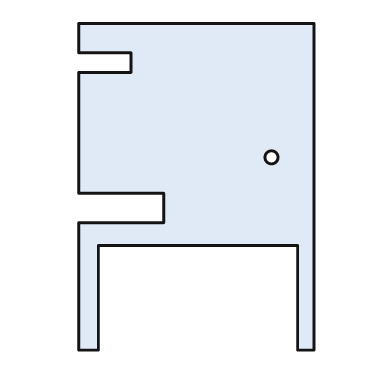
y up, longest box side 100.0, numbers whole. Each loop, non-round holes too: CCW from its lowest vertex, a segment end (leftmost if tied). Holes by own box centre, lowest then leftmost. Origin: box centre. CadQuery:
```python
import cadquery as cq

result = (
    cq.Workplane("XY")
    .moveTo(-36.0, -50.0)
    .lineTo(-30.0, -50.0)
    .lineTo(-30.0, -18.0)
    .lineTo(31.0, -18.0)
    .lineTo(31.0, -50.0)
    .lineTo(36.0, -50.0)
    .lineTo(36.0, 50.0)
    .lineTo(-36.0, 50.0)
    .lineTo(-36.0, 41.0)
    .lineTo(-20.0, 41.0)
    .lineTo(-20.0, 35.0)
    .lineTo(-36.0, 35.0)
    .lineTo(-36.0, -2.0)
    .lineTo(-10.0, -2.0)
    .lineTo(-10.0, -11.0)
    .lineTo(-36.0, -11.0)
    .close()
    .moveTo(23.0, 9.0)
    .circle(2.0)
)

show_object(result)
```